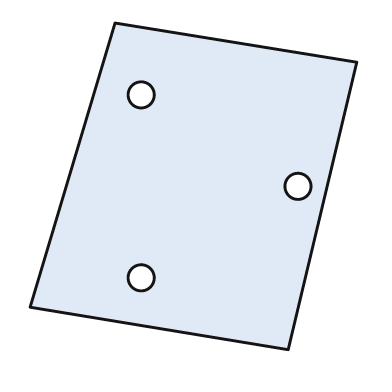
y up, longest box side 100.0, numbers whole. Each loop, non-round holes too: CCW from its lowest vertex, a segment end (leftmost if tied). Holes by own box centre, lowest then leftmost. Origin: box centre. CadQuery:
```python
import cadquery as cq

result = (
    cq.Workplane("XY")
    .moveTo(29.0, -50.0)
    .lineTo(50.0, 38.0)
    .lineTo(-24.0, 50.0)
    .lineTo(-50.0, -37.0)
    .close()
    .moveTo(-16.0, -28.0)
    .circle(4.0)
    .moveTo(32.0, 0.0)
    .circle(4.0)
    .moveTo(-16.0, 28.0)
    .circle(4.0)
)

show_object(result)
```